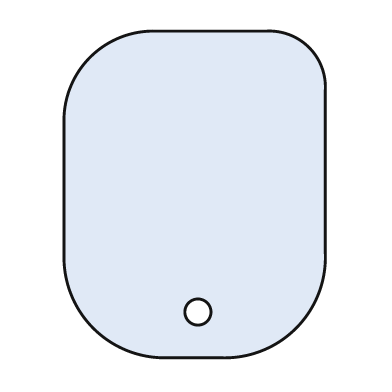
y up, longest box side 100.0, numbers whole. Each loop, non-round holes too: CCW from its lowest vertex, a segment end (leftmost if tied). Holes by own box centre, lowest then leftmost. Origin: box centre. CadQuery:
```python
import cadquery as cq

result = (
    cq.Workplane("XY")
    .moveTo(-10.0, -50.0)
    .lineTo(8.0, -50.0)
    .threePointArc((31.0, -41.0), (40.0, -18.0))
    .lineTo(40.0, 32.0)
    .threePointArc((35.0, 45.0), (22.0, 50.0))
    .lineTo(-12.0, 50.0)
    .threePointArc((-32.0, 42.0), (-40.0, 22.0))
    .lineTo(-40.0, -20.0)
    .threePointArc((-31.0, -41.0), (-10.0, -50.0))
    .close()
    .moveTo(1.0, -36.0)
    .circle(4.0)
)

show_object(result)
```